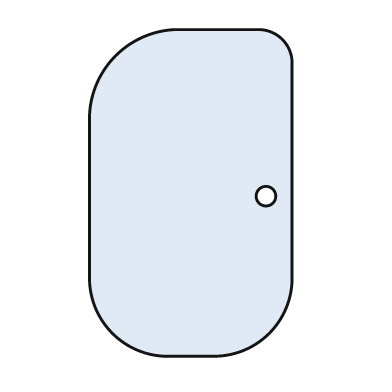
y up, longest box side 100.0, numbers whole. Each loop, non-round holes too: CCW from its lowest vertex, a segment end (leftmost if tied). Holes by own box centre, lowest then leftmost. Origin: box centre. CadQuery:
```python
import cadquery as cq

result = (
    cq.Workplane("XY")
    .moveTo(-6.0, -50.0)
    .lineTo(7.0, -50.0)
    .threePointArc((24.0, -43.0), (31.0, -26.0))
    .lineTo(31.0, 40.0)
    .threePointArc((28.0, 47.0), (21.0, 50.0))
    .lineTo(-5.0, 50.0)
    .threePointArc((-23.0, 42.0), (-31.0, 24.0))
    .lineTo(-31.0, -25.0)
    .threePointArc((-24.0, -43.0), (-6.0, -50.0))
    .close()
    .moveTo(23.0, -1.0)
    .circle(3.0)
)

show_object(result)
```